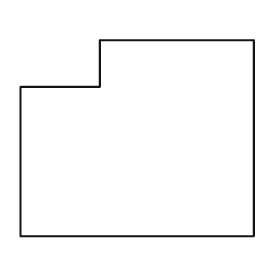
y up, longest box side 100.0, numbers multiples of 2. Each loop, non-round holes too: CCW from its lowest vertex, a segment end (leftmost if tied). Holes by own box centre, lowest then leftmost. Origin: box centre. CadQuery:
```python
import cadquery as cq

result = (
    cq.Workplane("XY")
    .moveTo(-50.0, -42.0)
    .lineTo(50.0, -42.0)
    .lineTo(50.0, 42.0)
    .lineTo(-16.0, 42.0)
    .lineTo(-16.0, 22.0)
    .lineTo(-50.0, 22.0)
    .close()
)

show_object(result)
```